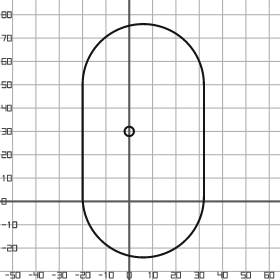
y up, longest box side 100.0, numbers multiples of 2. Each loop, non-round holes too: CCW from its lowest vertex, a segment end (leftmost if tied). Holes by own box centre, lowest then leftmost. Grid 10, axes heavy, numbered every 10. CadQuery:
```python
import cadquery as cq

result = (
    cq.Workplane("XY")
    .moveTo(-20.0, 2.0)
    .threePointArc((6.0, -24.0), (32.0, 2.0))
    .lineTo(32.0, 50.0)
    .threePointArc((6.0, 76.0), (-20.0, 50.0))
    .close()
    .moveTo(0.0, 30.0)
    .circle(2.0)
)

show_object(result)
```